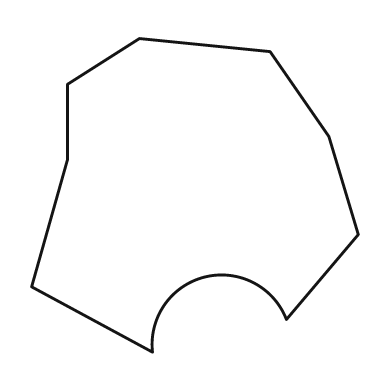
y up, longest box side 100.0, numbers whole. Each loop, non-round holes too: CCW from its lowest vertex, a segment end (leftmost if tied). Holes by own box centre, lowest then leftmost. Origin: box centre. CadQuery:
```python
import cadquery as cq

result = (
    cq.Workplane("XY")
    .moveTo(-13.0, -48.0)
    .threePointArc((3.0, -25.0), (28.0, -38.0))
    .lineTo(50.0, -12.0)
    .lineTo(41.0, 18.0)
    .lineTo(23.0, 44.0)
    .lineTo(-17.0, 48.0)
    .lineTo(-39.0, 34.0)
    .lineTo(-39.0, 11.0)
    .lineTo(-50.0, -28.0)
    .close()
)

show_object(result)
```